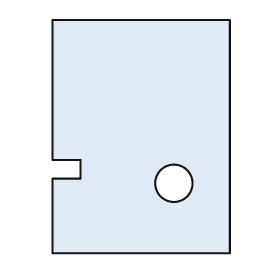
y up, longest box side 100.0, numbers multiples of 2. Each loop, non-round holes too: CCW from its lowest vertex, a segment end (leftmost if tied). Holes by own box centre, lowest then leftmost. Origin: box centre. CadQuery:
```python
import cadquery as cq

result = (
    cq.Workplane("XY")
    .moveTo(-38.0, -50.0)
    .lineTo(38.0, -50.0)
    .lineTo(38.0, 50.0)
    .lineTo(-38.0, 50.0)
    .lineTo(-38.0, -10.0)
    .lineTo(-26.0, -10.0)
    .lineTo(-26.0, -18.0)
    .lineTo(-38.0, -18.0)
    .close()
    .moveTo(14.0, -20.0)
    .circle(8.0)
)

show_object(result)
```